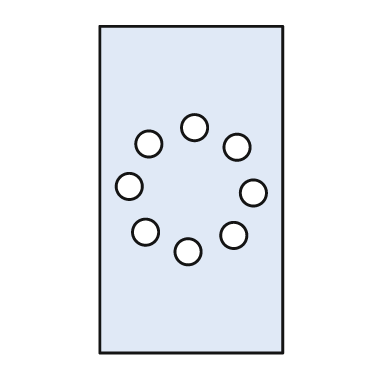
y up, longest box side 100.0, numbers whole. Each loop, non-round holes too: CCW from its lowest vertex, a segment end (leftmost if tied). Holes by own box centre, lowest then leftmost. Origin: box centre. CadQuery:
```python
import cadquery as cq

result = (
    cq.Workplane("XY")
    .moveTo(-28.0, -50.0)
    .lineTo(28.0, -50.0)
    .lineTo(28.0, 50.0)
    .lineTo(-28.0, 50.0)
    .close()
    .moveTo(-1.0, -19.0)
    .circle(4.0)
    .moveTo(13.0, -14.0)
    .circle(4.0)
    .moveTo(-14.0, -13.0)
    .circle(4.0)
    .moveTo(19.0, -1.0)
    .circle(4.0)
    .moveTo(-19.0, 1.0)
    .circle(4.0)
    .moveTo(14.0, 13.0)
    .circle(4.0)
    .moveTo(-13.0, 14.0)
    .circle(4.0)
    .moveTo(1.0, 19.0)
    .circle(4.0)
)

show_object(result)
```